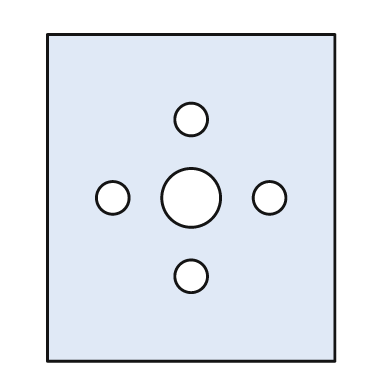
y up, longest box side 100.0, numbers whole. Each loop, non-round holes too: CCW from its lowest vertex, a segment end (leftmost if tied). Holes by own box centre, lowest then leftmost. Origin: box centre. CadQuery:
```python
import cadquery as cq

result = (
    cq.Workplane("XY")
    .moveTo(-44.0, -50.0)
    .lineTo(44.0, -50.0)
    .lineTo(44.0, 50.0)
    .lineTo(-44.0, 50.0)
    .close()
    .moveTo(0.0, -24.0)
    .circle(5.0)
    .moveTo(-24.0, 0.0)
    .circle(5.0)
    .moveTo(0.0, 0.0)
    .circle(9.0)
    .moveTo(24.0, 0.0)
    .circle(5.0)
    .moveTo(0.0, 24.0)
    .circle(5.0)
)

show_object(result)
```